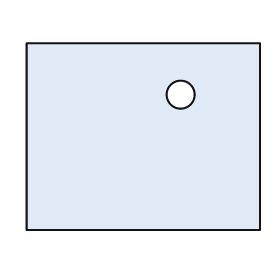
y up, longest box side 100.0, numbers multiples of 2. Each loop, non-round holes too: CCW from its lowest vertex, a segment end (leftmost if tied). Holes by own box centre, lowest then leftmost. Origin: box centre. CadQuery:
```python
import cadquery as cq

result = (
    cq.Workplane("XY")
    .moveTo(-50.0, -40.0)
    .lineTo(50.0, -40.0)
    .lineTo(50.0, 40.0)
    .lineTo(-50.0, 40.0)
    .close()
    .moveTo(16.0, 18.0)
    .circle(6.0)
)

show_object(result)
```